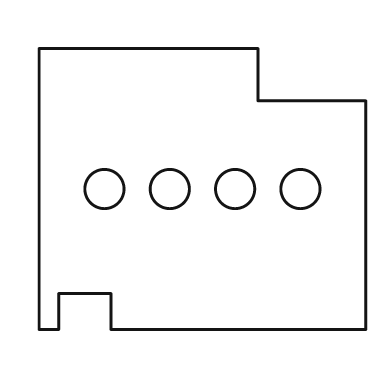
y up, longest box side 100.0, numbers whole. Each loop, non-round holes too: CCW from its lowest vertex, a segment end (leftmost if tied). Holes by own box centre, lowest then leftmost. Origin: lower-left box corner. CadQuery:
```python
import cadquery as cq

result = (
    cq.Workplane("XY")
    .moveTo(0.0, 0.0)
    .lineTo(6.0, 0.0)
    .lineTo(6.0, 11.0)
    .lineTo(22.0, 11.0)
    .lineTo(22.0, 0.0)
    .lineTo(100.0, 0.0)
    .lineTo(100.0, 70.0)
    .lineTo(67.0, 70.0)
    .lineTo(67.0, 86.0)
    .lineTo(0.0, 86.0)
    .close()
    .moveTo(20.0, 43.0)
    .circle(6.0)
    .moveTo(40.0, 43.0)
    .circle(6.0)
    .moveTo(60.0, 43.0)
    .circle(6.0)
    .moveTo(80.0, 43.0)
    .circle(6.0)
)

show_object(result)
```